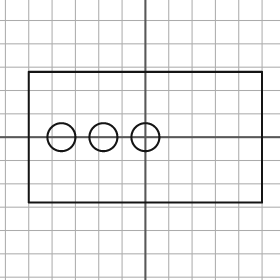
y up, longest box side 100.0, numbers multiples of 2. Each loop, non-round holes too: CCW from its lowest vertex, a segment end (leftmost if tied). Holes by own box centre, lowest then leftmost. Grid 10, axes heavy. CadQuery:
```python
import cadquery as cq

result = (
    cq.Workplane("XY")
    .moveTo(-50.0, -28.0)
    .lineTo(50.0, -28.0)
    .lineTo(50.0, 28.0)
    .lineTo(-50.0, 28.0)
    .close()
    .moveTo(-36.0, 0.0)
    .circle(6.0)
    .moveTo(-18.0, 0.0)
    .circle(6.0)
    .moveTo(0.0, 0.0)
    .circle(6.0)
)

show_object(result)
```